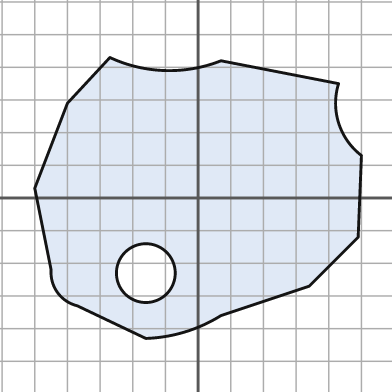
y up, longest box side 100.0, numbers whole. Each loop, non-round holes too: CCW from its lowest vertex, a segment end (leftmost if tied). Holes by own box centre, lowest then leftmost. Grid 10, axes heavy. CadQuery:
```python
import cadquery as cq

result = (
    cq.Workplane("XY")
    .moveTo(-16.0, -43.0)
    .threePointArc((-4.0, -41.0), (7.0, -36.0))
    .lineTo(34.0, -27.0)
    .lineTo(49.0, -12.0)
    .lineTo(50.0, 13.0)
    .threePointArc((43.0, 23.0), (43.0, 35.0))
    .lineTo(7.0, 42.0)
    .threePointArc((-10.0, 39.0), (-27.0, 43.0))
    .lineTo(-40.0, 29.0)
    .lineTo(-50.0, 3.0)
    .lineTo(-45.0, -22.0)
    .threePointArc((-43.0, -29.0), (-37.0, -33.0))
    .close()
    .moveTo(-16.0, -23.0)
    .circle(9.0)
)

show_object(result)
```